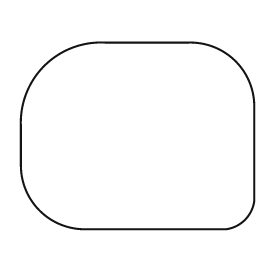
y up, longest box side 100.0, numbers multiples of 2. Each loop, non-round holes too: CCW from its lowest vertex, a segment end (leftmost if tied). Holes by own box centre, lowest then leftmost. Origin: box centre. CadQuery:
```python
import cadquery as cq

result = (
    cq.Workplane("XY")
    .moveTo(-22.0, -40.0)
    .lineTo(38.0, -40.0)
    .threePointArc((46.0, -36.0), (50.0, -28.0))
    .lineTo(50.0, 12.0)
    .threePointArc((42.0, 32.0), (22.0, 40.0))
    .lineTo(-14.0, 40.0)
    .threePointArc((-40.0, 30.0), (-50.0, 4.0))
    .lineTo(-50.0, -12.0)
    .threePointArc((-42.0, -32.0), (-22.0, -40.0))
    .close()
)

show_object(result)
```